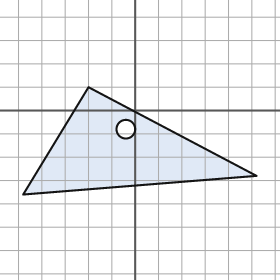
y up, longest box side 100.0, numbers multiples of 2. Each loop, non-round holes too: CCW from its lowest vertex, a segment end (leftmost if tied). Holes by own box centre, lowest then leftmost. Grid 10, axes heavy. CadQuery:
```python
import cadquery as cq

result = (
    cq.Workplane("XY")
    .moveTo(-48.0, -36.0)
    .lineTo(52.0, -28.0)
    .lineTo(-20.0, 10.0)
    .close()
    .moveTo(-4.0, -8.0)
    .circle(4.0)
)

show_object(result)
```